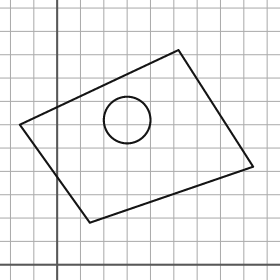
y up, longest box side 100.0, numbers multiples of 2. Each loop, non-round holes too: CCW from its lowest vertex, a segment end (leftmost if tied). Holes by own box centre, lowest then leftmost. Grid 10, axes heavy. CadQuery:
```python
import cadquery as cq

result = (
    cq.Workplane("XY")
    .moveTo(14.0, 18.0)
    .lineTo(84.0, 42.0)
    .lineTo(52.0, 92.0)
    .lineTo(-16.0, 60.0)
    .close()
    .moveTo(30.0, 62.0)
    .circle(10.0)
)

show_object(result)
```